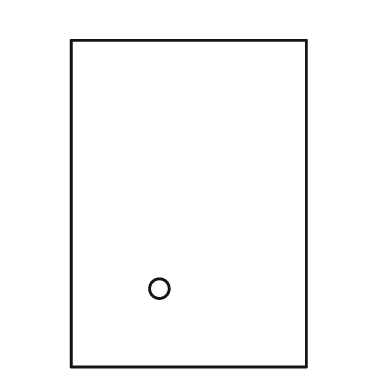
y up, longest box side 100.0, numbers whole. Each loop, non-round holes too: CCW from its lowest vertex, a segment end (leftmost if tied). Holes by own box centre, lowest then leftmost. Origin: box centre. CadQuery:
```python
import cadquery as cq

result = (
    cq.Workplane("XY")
    .moveTo(-36.0, -50.0)
    .lineTo(36.0, -50.0)
    .lineTo(36.0, 50.0)
    .lineTo(-36.0, 50.0)
    .close()
    .moveTo(-9.0, -26.0)
    .circle(3.0)
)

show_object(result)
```